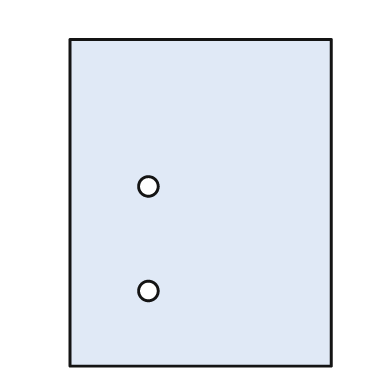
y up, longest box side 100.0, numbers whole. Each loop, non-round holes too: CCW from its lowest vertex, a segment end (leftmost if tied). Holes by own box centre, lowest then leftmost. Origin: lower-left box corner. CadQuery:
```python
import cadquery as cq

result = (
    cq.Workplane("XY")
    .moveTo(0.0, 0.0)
    .lineTo(80.0, 0.0)
    .lineTo(80.0, 100.0)
    .lineTo(0.0, 100.0)
    .close()
    .moveTo(24.0, 23.0)
    .circle(3.0)
    .moveTo(24.0, 55.0)
    .circle(3.0)
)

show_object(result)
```